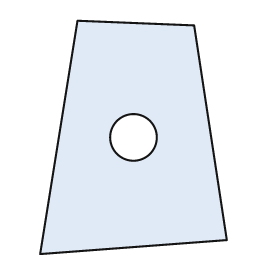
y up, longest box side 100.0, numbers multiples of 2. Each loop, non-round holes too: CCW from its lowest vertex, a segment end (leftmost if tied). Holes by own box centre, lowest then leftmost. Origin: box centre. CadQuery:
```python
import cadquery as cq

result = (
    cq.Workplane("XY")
    .moveTo(-40.0, -50.0)
    .lineTo(40.0, -44.0)
    .lineTo(26.0, 48.0)
    .lineTo(-24.0, 50.0)
    .close()
    .moveTo(0.0, 0.0)
    .circle(10.0)
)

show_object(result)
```